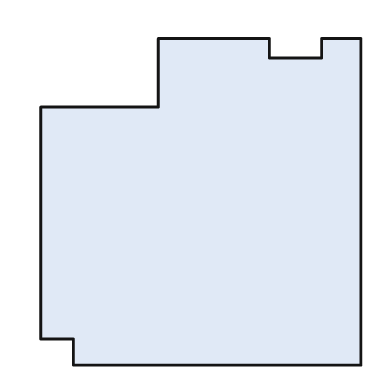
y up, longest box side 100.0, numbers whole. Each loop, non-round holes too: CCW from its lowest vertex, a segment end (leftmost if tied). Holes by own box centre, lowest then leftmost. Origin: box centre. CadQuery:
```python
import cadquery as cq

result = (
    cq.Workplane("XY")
    .moveTo(-39.0, -50.0)
    .lineTo(49.0, -50.0)
    .lineTo(49.0, 50.0)
    .lineTo(37.0, 50.0)
    .lineTo(37.0, 44.0)
    .lineTo(21.0, 44.0)
    .lineTo(21.0, 50.0)
    .lineTo(-13.0, 50.0)
    .lineTo(-13.0, 29.0)
    .lineTo(-49.0, 29.0)
    .lineTo(-49.0, -42.0)
    .lineTo(-39.0, -42.0)
    .close()
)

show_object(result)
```